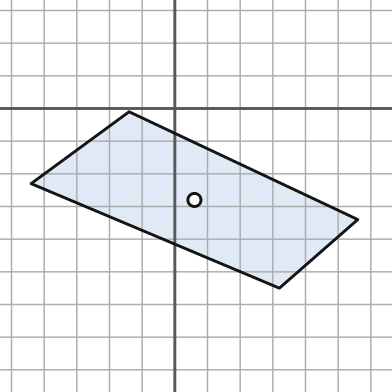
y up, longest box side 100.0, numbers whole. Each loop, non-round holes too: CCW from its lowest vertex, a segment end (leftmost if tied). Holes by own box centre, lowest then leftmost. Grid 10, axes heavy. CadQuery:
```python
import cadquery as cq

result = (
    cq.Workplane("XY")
    .moveTo(32.0, -55.0)
    .lineTo(56.0, -34.0)
    .lineTo(-14.0, -1.0)
    .lineTo(-44.0, -23.0)
    .close()
    .moveTo(6.0, -28.0)
    .circle(2.0)
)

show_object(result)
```